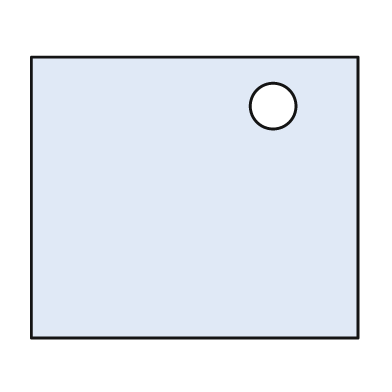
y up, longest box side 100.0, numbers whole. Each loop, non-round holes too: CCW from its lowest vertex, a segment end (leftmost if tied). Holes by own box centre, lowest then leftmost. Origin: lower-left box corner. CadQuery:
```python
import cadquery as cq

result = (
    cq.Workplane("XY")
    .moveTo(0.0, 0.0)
    .lineTo(100.0, 0.0)
    .lineTo(100.0, 86.0)
    .lineTo(0.0, 86.0)
    .close()
    .moveTo(74.0, 71.0)
    .circle(7.0)
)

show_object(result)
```